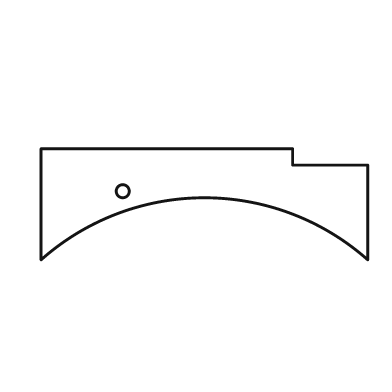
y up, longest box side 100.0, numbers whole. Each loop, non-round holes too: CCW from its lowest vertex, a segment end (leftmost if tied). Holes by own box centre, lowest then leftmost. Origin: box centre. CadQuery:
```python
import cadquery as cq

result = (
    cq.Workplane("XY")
    .moveTo(-50.0, -17.0)
    .threePointArc((0.0, 2.0), (50.0, -17.0))
    .lineTo(50.0, 12.0)
    .lineTo(27.0, 12.0)
    .lineTo(27.0, 17.0)
    .lineTo(-50.0, 17.0)
    .close()
    .moveTo(-25.0, 4.0)
    .circle(2.0)
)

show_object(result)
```